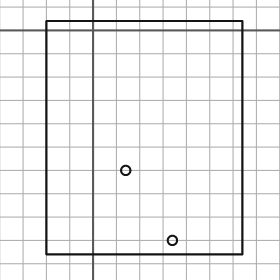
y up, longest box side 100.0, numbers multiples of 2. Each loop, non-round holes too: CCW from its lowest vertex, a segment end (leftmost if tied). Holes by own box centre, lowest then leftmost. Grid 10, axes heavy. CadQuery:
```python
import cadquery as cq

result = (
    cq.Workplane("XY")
    .moveTo(-20.0, -96.0)
    .lineTo(64.0, -96.0)
    .lineTo(64.0, 4.0)
    .lineTo(-20.0, 4.0)
    .close()
    .moveTo(34.0, -90.0)
    .circle(2.0)
    .moveTo(14.0, -60.0)
    .circle(2.0)
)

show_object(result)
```